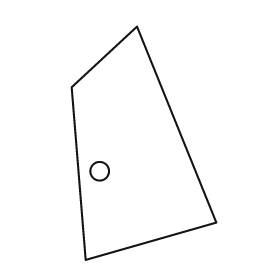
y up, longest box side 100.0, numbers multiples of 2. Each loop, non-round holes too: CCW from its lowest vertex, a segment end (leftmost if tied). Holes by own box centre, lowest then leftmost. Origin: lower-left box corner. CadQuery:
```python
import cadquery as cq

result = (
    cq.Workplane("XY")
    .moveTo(6.0, 0.0)
    .lineTo(62.0, 16.0)
    .lineTo(28.0, 100.0)
    .lineTo(0.0, 74.0)
    .close()
    .moveTo(12.0, 38.0)
    .circle(4.0)
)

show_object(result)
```